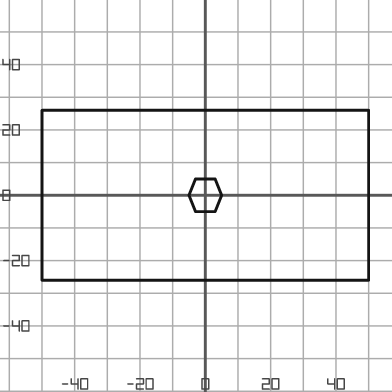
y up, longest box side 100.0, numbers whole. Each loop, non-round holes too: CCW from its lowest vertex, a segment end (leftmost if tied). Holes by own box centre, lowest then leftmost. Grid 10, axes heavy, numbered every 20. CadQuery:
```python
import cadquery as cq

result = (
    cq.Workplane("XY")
    .moveTo(-50.0, -26.0)
    .lineTo(50.0, -26.0)
    .lineTo(50.0, 26.0)
    .lineTo(-50.0, 26.0)
    .close()
    .moveTo(-3.0, -5.0)
    .lineTo(3.0, -5.0)
    .lineTo(5.0, 0.0)
    .lineTo(3.0, 5.0)
    .lineTo(-3.0, 5.0)
    .lineTo(-5.0, 0.0)
    .close()
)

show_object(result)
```